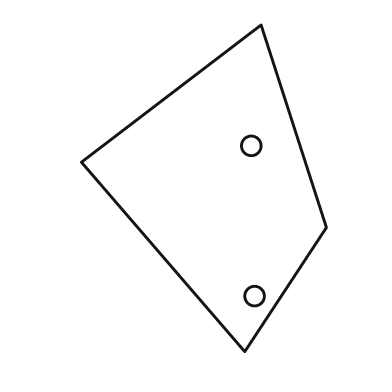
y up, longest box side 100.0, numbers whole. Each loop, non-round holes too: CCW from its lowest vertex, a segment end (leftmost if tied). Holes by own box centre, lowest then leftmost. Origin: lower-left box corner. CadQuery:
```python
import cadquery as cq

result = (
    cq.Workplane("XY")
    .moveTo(50.0, 0.0)
    .lineTo(75.0, 38.0)
    .lineTo(55.0, 100.0)
    .lineTo(0.0, 58.0)
    .close()
    .moveTo(53.0, 17.0)
    .circle(3.0)
    .moveTo(52.0, 63.0)
    .circle(3.0)
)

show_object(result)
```